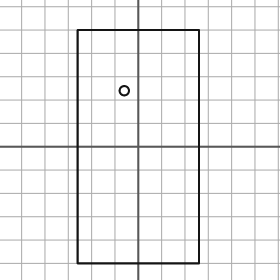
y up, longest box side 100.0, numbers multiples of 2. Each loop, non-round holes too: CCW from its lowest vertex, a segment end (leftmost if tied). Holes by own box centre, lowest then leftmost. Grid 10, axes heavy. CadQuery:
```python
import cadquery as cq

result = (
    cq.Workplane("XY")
    .moveTo(-26.0, -50.0)
    .lineTo(26.0, -50.0)
    .lineTo(26.0, 50.0)
    .lineTo(-26.0, 50.0)
    .close()
    .moveTo(-6.0, 24.0)
    .circle(2.0)
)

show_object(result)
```